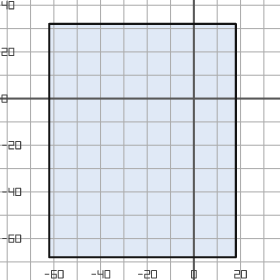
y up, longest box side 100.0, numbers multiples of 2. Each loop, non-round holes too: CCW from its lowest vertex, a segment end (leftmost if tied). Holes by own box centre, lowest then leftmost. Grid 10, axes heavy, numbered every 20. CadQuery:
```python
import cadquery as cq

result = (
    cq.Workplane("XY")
    .moveTo(-62.0, -68.0)
    .lineTo(18.0, -68.0)
    .lineTo(18.0, 32.0)
    .lineTo(-62.0, 32.0)
    .close()
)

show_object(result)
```